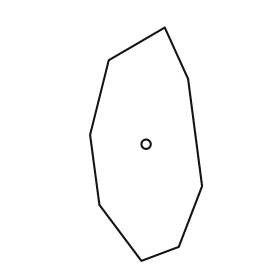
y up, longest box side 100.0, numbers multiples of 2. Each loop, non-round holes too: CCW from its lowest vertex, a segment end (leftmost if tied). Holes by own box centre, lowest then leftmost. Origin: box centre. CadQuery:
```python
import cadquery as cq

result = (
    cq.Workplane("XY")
    .moveTo(-2.0, -50.0)
    .lineTo(14.0, -44.0)
    .lineTo(24.0, -18.0)
    .lineTo(18.0, 28.0)
    .lineTo(8.0, 50.0)
    .lineTo(-16.0, 36.0)
    .lineTo(-24.0, 4.0)
    .lineTo(-20.0, -26.0)
    .close()
    .moveTo(0.0, 0.0)
    .circle(2.0)
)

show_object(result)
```